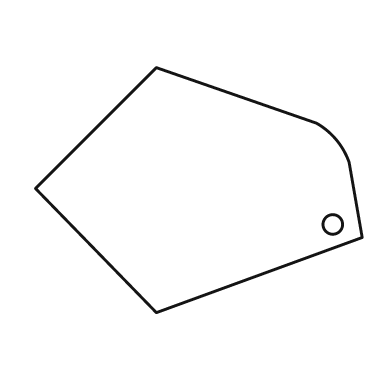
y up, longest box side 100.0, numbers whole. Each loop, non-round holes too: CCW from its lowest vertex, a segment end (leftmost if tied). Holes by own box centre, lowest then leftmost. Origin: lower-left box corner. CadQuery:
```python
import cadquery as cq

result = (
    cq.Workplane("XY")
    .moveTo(37.0, 0.0)
    .lineTo(100.0, 23.0)
    .lineTo(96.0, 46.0)
    .threePointArc((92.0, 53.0), (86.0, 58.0))
    .lineTo(37.0, 75.0)
    .lineTo(0.0, 38.0)
    .close()
    .moveTo(91.0, 27.0)
    .circle(3.0)
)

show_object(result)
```